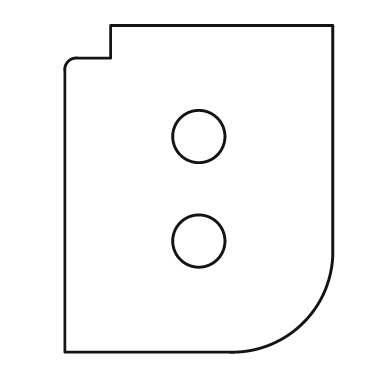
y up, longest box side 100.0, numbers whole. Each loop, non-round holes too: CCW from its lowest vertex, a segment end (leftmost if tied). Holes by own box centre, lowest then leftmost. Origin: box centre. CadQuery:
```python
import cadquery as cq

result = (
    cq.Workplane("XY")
    .moveTo(-41.0, -50.0)
    .lineTo(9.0, -50.0)
    .threePointArc((32.0, -41.0), (41.0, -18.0))
    .lineTo(41.0, 50.0)
    .lineTo(-27.0, 50.0)
    .lineTo(-27.0, 40.0)
    .lineTo(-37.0, 40.0)
    .threePointArc((-40.0, 39.0), (-41.0, 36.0))
    .close()
    .moveTo(0.0, -16.0)
    .circle(8.0)
    .moveTo(0.0, 16.0)
    .circle(8.0)
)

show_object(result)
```